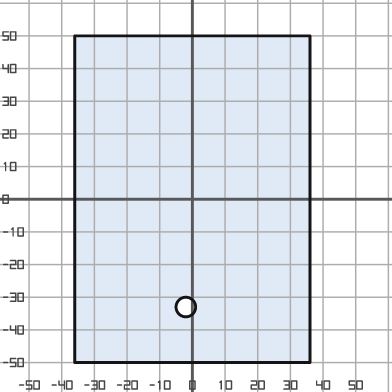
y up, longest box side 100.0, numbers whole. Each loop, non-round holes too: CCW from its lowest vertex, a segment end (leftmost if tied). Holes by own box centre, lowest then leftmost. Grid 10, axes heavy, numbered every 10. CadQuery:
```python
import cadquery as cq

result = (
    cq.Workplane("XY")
    .moveTo(-36.0, -50.0)
    .lineTo(36.0, -50.0)
    .lineTo(36.0, 50.0)
    .lineTo(-36.0, 50.0)
    .close()
    .moveTo(-2.0, -33.0)
    .circle(3.0)
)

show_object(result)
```